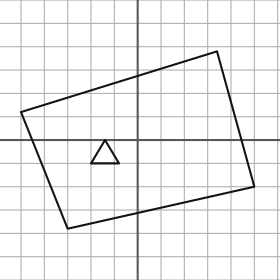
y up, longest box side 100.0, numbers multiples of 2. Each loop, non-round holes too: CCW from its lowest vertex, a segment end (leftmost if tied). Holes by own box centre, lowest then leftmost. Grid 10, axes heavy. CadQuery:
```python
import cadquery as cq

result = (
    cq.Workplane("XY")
    .moveTo(-30.0, -38.0)
    .lineTo(50.0, -20.0)
    .lineTo(34.0, 38.0)
    .lineTo(-50.0, 12.0)
    .close()
    .moveTo(-20.0, -10.0)
    .lineTo(-8.0, -10.0)
    .lineTo(-14.0, 0.0)
    .close()
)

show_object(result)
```